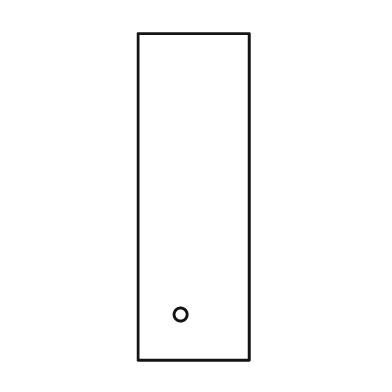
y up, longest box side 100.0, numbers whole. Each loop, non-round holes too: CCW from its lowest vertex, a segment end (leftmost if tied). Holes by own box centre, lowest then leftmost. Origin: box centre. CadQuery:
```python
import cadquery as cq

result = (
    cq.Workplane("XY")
    .moveTo(-17.0, -50.0)
    .lineTo(17.0, -50.0)
    .lineTo(17.0, 50.0)
    .lineTo(-17.0, 50.0)
    .close()
    .moveTo(-4.0, -36.0)
    .circle(2.0)
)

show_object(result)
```